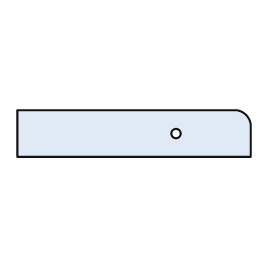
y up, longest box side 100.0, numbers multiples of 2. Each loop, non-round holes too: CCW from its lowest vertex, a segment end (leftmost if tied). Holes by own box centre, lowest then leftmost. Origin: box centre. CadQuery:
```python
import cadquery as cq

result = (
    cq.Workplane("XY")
    .moveTo(-50.0, -10.0)
    .lineTo(50.0, -10.0)
    .lineTo(50.0, 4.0)
    .threePointArc((48.0, 8.0), (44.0, 10.0))
    .lineTo(-50.0, 10.0)
    .close()
    .moveTo(18.0, 0.0)
    .circle(2.0)
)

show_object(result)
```